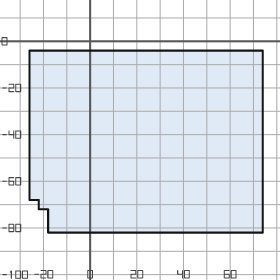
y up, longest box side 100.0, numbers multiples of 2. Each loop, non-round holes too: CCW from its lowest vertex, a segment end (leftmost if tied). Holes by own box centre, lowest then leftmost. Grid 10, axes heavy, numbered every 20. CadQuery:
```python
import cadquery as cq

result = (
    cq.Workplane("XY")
    .moveTo(-18.0, -82.0)
    .lineTo(74.0, -82.0)
    .lineTo(74.0, -4.0)
    .lineTo(-26.0, -4.0)
    .lineTo(-26.0, -68.0)
    .lineTo(-22.0, -68.0)
    .lineTo(-22.0, -72.0)
    .lineTo(-18.0, -72.0)
    .close()
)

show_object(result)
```